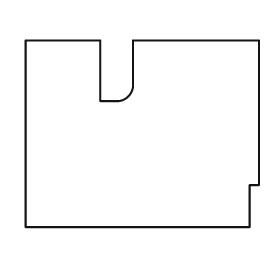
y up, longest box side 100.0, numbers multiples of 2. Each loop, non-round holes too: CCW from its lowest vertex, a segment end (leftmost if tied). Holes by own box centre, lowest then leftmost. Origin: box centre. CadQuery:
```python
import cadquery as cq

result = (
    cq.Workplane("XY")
    .moveTo(-50.0, -40.0)
    .lineTo(46.0, -40.0)
    .lineTo(46.0, -22.0)
    .lineTo(50.0, -22.0)
    .lineTo(50.0, 40.0)
    .lineTo(-4.0, 40.0)
    .lineTo(-4.0, 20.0)
    .threePointArc((-6.0, 16.0), (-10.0, 14.0))
    .lineTo(-18.0, 14.0)
    .lineTo(-18.0, 40.0)
    .lineTo(-50.0, 40.0)
    .close()
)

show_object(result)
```